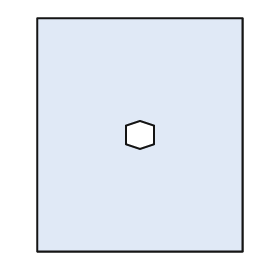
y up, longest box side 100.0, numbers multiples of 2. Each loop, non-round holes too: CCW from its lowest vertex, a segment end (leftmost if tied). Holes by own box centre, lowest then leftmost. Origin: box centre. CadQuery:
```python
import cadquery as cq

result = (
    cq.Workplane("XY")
    .moveTo(-44.0, -50.0)
    .lineTo(44.0, -50.0)
    .lineTo(44.0, 50.0)
    .lineTo(-44.0, 50.0)
    .close()
    .moveTo(0.0, -6.0)
    .lineTo(6.0, -4.0)
    .lineTo(6.0, 4.0)
    .lineTo(0.0, 6.0)
    .lineTo(-6.0, 4.0)
    .lineTo(-6.0, -4.0)
    .close()
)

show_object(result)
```